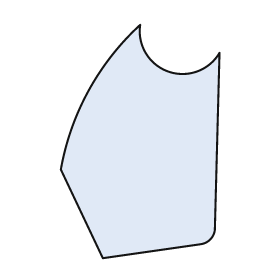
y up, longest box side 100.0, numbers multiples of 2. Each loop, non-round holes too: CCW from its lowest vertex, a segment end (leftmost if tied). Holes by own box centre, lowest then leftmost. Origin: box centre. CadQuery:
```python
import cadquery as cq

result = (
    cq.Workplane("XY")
    .moveTo(-16.0, -50.0)
    .lineTo(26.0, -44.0)
    .threePointArc((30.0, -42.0), (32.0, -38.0))
    .lineTo(34.0, 38.0)
    .threePointArc((12.0, 30.0), (0.0, 50.0))
    .threePointArc((-22.0, 22.0), (-34.0, -12.0))
    .close()
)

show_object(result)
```